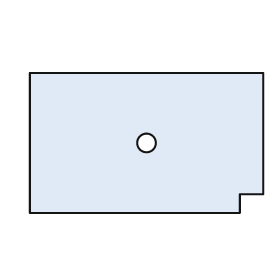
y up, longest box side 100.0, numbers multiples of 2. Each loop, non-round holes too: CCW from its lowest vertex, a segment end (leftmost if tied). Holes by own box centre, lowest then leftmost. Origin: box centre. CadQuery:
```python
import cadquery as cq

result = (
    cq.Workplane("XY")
    .moveTo(-50.0, -30.0)
    .lineTo(40.0, -30.0)
    .lineTo(40.0, -22.0)
    .lineTo(50.0, -22.0)
    .lineTo(50.0, 30.0)
    .lineTo(-50.0, 30.0)
    .close()
    .moveTo(0.0, 0.0)
    .circle(4.0)
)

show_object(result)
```